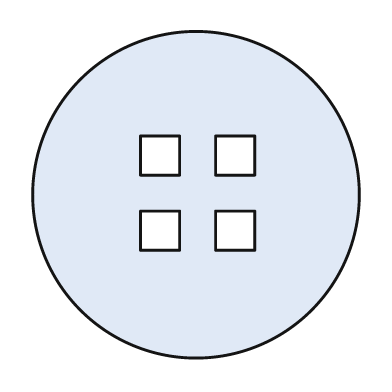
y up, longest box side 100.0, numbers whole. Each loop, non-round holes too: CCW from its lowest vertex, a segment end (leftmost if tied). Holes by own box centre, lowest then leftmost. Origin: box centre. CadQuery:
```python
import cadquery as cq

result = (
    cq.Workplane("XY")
    .moveTo(0.0, 0.0)
    .circle(50.0)
    .moveTo(-17.0, -17.0)
    .lineTo(-5.0, -17.0)
    .lineTo(-5.0, -5.0)
    .lineTo(-17.0, -5.0)
    .close()
    .moveTo(6.0, -17.0)
    .lineTo(18.0, -17.0)
    .lineTo(18.0, -5.0)
    .lineTo(6.0, -5.0)
    .close()
    .moveTo(-17.0, 6.0)
    .lineTo(-5.0, 6.0)
    .lineTo(-5.0, 18.0)
    .lineTo(-17.0, 18.0)
    .close()
    .moveTo(6.0, 6.0)
    .lineTo(18.0, 6.0)
    .lineTo(18.0, 18.0)
    .lineTo(6.0, 18.0)
    .close()
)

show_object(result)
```